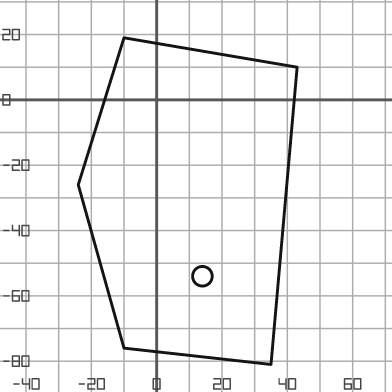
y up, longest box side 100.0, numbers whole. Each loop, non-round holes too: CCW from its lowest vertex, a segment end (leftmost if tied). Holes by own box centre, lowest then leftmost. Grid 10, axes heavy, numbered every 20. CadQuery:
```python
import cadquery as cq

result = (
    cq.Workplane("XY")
    .moveTo(35.0, -81.0)
    .lineTo(43.0, 10.0)
    .lineTo(-10.0, 19.0)
    .lineTo(-24.0, -26.0)
    .lineTo(-10.0, -76.0)
    .close()
    .moveTo(14.0, -54.0)
    .circle(3.0)
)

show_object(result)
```